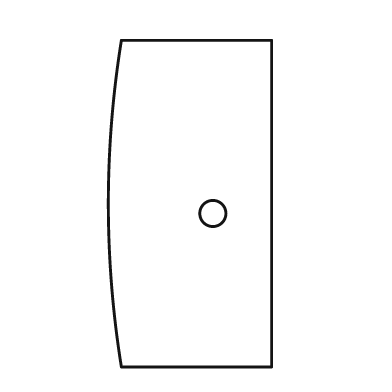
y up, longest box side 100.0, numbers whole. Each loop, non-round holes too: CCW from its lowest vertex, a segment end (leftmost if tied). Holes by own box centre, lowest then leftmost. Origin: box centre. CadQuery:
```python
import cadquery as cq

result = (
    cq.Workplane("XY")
    .moveTo(-21.0, -50.0)
    .lineTo(25.0, -50.0)
    .lineTo(25.0, 50.0)
    .lineTo(-21.0, 50.0)
    .threePointArc((-25.0, 0.0), (-21.0, -50.0))
    .close()
    .moveTo(7.0, -3.0)
    .circle(4.0)
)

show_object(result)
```